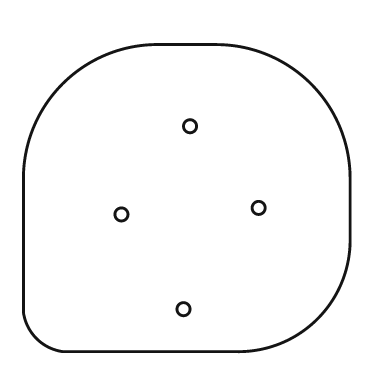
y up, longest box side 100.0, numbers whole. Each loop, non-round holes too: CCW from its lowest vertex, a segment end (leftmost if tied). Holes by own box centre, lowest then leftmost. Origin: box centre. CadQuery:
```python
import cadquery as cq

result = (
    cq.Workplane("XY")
    .moveTo(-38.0, -47.0)
    .lineTo(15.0, -47.0)
    .threePointArc((40.0, -37.0), (50.0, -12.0))
    .lineTo(50.0, 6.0)
    .threePointArc((38.0, 35.0), (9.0, 47.0))
    .lineTo(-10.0, 47.0)
    .threePointArc((-38.0, 35.0), (-50.0, 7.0))
    .lineTo(-50.0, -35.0)
    .threePointArc((-46.0, -43.0), (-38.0, -47.0))
    .close()
    .moveTo(-1.0, -34.0)
    .circle(2.0)
    .moveTo(-20.0, -5.0)
    .circle(2.0)
    .moveTo(22.0, -3.0)
    .circle(2.0)
    .moveTo(1.0, 22.0)
    .circle(2.0)
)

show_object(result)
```